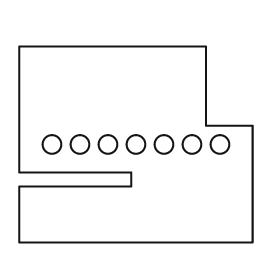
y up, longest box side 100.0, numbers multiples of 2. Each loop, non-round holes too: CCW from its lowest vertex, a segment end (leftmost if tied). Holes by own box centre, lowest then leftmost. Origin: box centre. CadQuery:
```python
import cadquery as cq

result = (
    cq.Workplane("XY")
    .moveTo(-50.0, -42.0)
    .lineTo(50.0, -42.0)
    .lineTo(50.0, 8.0)
    .lineTo(30.0, 8.0)
    .lineTo(30.0, 42.0)
    .lineTo(-50.0, 42.0)
    .lineTo(-50.0, -12.0)
    .lineTo(-2.0, -12.0)
    .lineTo(-2.0, -18.0)
    .lineTo(-50.0, -18.0)
    .close()
    .moveTo(-36.0, 0.0)
    .circle(4.0)
    .moveTo(-24.0, 0.0)
    .circle(4.0)
    .moveTo(-12.0, 0.0)
    .circle(4.0)
    .moveTo(0.0, 0.0)
    .circle(4.0)
    .moveTo(12.0, 0.0)
    .circle(4.0)
    .moveTo(24.0, 0.0)
    .circle(4.0)
    .moveTo(36.0, 0.0)
    .circle(4.0)
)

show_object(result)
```